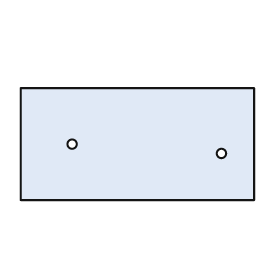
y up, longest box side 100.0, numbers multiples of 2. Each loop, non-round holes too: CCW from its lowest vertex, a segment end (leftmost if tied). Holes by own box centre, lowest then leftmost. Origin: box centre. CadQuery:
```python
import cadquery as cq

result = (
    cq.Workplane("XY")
    .moveTo(-50.0, -24.0)
    .lineTo(50.0, -24.0)
    .lineTo(50.0, 24.0)
    .lineTo(-50.0, 24.0)
    .close()
    .moveTo(36.0, -4.0)
    .circle(2.0)
    .moveTo(-28.0, 0.0)
    .circle(2.0)
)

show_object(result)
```